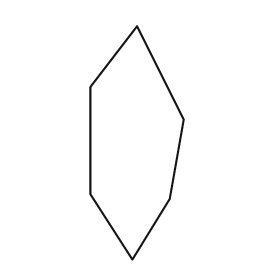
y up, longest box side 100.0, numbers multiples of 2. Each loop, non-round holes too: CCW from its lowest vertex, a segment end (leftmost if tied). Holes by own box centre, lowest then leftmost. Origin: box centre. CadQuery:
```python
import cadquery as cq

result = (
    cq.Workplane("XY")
    .moveTo(-2.0, -50.0)
    .lineTo(14.0, -24.0)
    .lineTo(20.0, 10.0)
    .lineTo(0.0, 50.0)
    .lineTo(-20.0, 24.0)
    .lineTo(-20.0, -22.0)
    .close()
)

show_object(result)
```